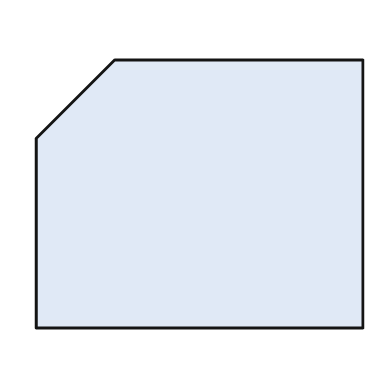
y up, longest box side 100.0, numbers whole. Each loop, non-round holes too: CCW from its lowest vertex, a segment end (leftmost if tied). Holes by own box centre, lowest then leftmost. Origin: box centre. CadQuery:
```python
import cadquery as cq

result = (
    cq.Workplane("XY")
    .moveTo(-50.0, -41.0)
    .lineTo(50.0, -41.0)
    .lineTo(50.0, 41.0)
    .lineTo(-26.0, 41.0)
    .lineTo(-50.0, 17.0)
    .close()
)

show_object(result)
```